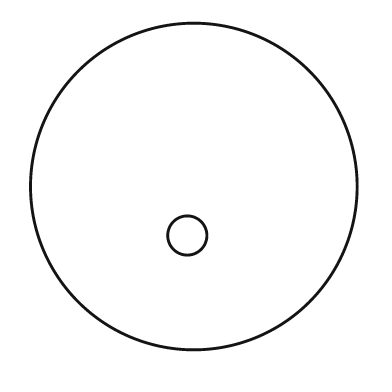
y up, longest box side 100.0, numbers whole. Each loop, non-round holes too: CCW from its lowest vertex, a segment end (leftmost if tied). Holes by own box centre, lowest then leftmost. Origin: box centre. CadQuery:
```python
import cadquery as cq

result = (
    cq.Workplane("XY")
    .moveTo(0.0, 0.0)
    .circle(50.0)
    .moveTo(-2.0, -15.0)
    .circle(6.0)
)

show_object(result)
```